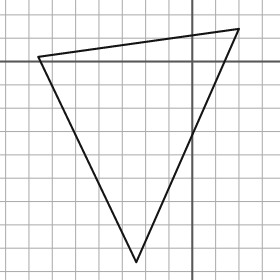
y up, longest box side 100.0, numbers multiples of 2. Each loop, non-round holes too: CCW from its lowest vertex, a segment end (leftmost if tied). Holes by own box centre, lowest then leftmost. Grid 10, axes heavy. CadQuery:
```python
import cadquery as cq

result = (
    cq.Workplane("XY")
    .moveTo(-24.0, -86.0)
    .lineTo(20.0, 14.0)
    .lineTo(-66.0, 2.0)
    .close()
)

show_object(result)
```